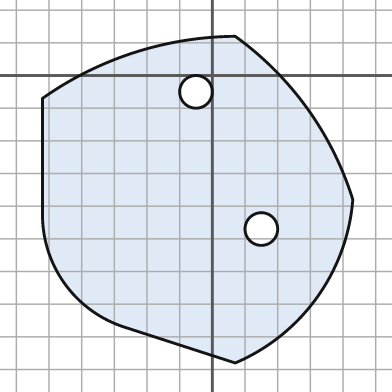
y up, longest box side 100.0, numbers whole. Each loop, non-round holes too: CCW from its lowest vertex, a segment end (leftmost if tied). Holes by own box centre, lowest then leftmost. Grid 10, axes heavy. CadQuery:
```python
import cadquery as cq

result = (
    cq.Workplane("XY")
    .moveTo(7.0, -88.0)
    .threePointArc((32.0, -68.0), (43.0, -38.0))
    .threePointArc((29.0, -10.0), (7.0, 12.0))
    .threePointArc((-24.0, 7.0), (-52.0, -7.0))
    .lineTo(-52.0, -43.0)
    .threePointArc((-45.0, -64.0), (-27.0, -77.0))
    .close()
    .moveTo(15.0, -47.0)
    .circle(5.0)
    .moveTo(-5.0, -5.0)
    .circle(5.0)
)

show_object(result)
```